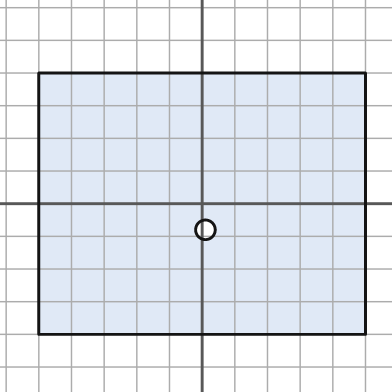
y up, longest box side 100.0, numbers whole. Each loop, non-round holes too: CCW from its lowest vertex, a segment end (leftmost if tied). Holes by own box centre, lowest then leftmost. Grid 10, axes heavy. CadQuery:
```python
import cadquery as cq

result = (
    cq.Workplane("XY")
    .moveTo(-50.0, -40.0)
    .lineTo(50.0, -40.0)
    .lineTo(50.0, 40.0)
    .lineTo(-50.0, 40.0)
    .close()
    .moveTo(1.0, -8.0)
    .circle(3.0)
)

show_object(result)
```